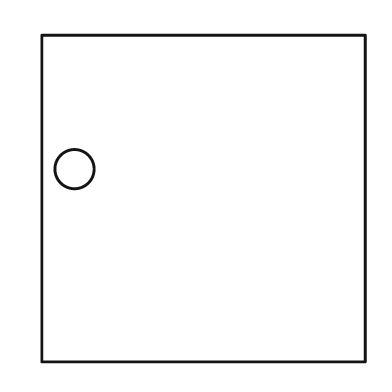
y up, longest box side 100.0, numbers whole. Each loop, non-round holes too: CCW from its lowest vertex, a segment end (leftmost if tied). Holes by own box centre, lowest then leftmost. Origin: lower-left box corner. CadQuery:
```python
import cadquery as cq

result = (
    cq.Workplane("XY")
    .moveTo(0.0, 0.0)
    .lineTo(99.0, 0.0)
    .lineTo(99.0, 100.0)
    .lineTo(0.0, 100.0)
    .close()
    .moveTo(10.0, 59.0)
    .circle(6.0)
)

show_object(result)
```